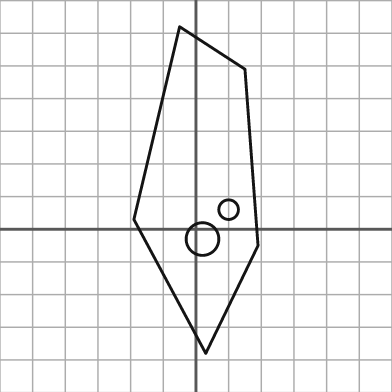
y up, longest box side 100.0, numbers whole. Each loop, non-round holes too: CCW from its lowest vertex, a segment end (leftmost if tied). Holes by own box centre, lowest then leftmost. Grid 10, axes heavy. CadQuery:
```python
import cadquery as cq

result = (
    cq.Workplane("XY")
    .moveTo(3.0, -38.0)
    .lineTo(19.0, -5.0)
    .lineTo(15.0, 49.0)
    .lineTo(-5.0, 62.0)
    .lineTo(-19.0, 3.0)
    .close()
    .moveTo(2.0, -3.0)
    .circle(5.0)
    .moveTo(10.0, 6.0)
    .circle(3.0)
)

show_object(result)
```